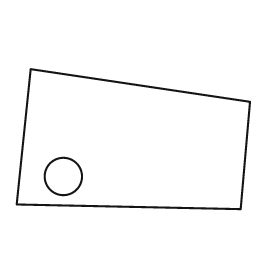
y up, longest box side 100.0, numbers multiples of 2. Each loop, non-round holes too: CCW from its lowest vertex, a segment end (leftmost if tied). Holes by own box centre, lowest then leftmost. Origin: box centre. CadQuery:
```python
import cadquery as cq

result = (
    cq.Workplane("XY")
    .moveTo(46.0, -30.0)
    .lineTo(50.0, 16.0)
    .lineTo(-44.0, 30.0)
    .lineTo(-50.0, -28.0)
    .close()
    .moveTo(-30.0, -16.0)
    .circle(8.0)
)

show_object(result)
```